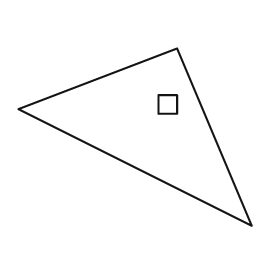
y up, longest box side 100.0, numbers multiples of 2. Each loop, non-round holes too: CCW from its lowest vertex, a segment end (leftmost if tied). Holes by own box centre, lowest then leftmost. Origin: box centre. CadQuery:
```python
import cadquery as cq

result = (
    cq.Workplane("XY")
    .moveTo(50.0, -38.0)
    .lineTo(18.0, 38.0)
    .lineTo(-50.0, 12.0)
    .close()
    .moveTo(10.0, 10.0)
    .lineTo(18.0, 10.0)
    .lineTo(18.0, 18.0)
    .lineTo(10.0, 18.0)
    .close()
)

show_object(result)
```